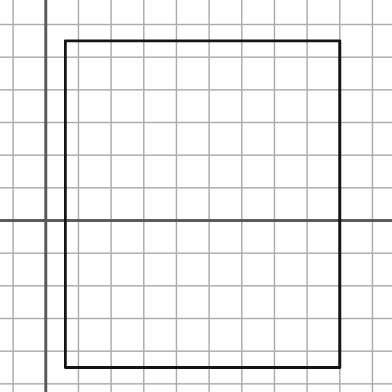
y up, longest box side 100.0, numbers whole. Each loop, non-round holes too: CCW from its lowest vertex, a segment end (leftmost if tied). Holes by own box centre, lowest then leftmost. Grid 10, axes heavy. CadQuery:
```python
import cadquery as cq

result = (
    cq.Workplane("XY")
    .moveTo(6.0, -45.0)
    .lineTo(90.0, -45.0)
    .lineTo(90.0, 55.0)
    .lineTo(6.0, 55.0)
    .close()
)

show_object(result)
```